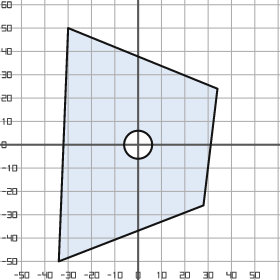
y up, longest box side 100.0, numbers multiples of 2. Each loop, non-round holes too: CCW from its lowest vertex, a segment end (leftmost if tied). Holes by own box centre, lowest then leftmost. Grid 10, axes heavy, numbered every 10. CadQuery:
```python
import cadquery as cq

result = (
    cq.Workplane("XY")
    .moveTo(-34.0, -50.0)
    .lineTo(28.0, -26.0)
    .lineTo(34.0, 24.0)
    .lineTo(-30.0, 50.0)
    .close()
    .moveTo(0.0, 0.0)
    .circle(6.0)
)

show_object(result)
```